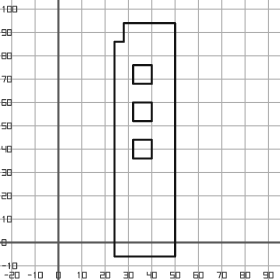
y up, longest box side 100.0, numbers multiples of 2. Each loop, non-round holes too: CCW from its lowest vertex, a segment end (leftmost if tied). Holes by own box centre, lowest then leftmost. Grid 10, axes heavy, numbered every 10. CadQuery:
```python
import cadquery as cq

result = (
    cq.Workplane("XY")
    .moveTo(24.0, -6.0)
    .lineTo(50.0, -6.0)
    .lineTo(50.0, 94.0)
    .lineTo(28.0, 94.0)
    .lineTo(28.0, 86.0)
    .lineTo(24.0, 86.0)
    .close()
    .moveTo(32.0, 36.0)
    .lineTo(40.0, 36.0)
    .lineTo(40.0, 44.0)
    .lineTo(32.0, 44.0)
    .close()
    .moveTo(32.0, 52.0)
    .lineTo(40.0, 52.0)
    .lineTo(40.0, 60.0)
    .lineTo(32.0, 60.0)
    .close()
    .moveTo(32.0, 68.0)
    .lineTo(40.0, 68.0)
    .lineTo(40.0, 76.0)
    .lineTo(32.0, 76.0)
    .close()
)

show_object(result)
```